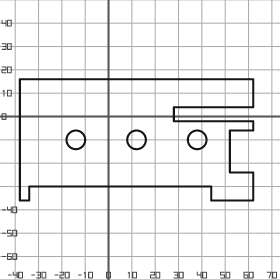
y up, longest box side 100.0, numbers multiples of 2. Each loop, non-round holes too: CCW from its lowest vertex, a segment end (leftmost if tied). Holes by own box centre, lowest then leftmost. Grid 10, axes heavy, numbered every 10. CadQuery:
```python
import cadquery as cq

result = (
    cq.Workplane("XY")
    .moveTo(-38.0, -36.0)
    .lineTo(-34.0, -36.0)
    .lineTo(-34.0, -30.0)
    .lineTo(44.0, -30.0)
    .lineTo(44.0, -36.0)
    .lineTo(62.0, -36.0)
    .lineTo(62.0, -24.0)
    .lineTo(52.0, -24.0)
    .lineTo(52.0, -6.0)
    .lineTo(62.0, -6.0)
    .lineTo(62.0, -2.0)
    .lineTo(28.0, -2.0)
    .lineTo(28.0, 4.0)
    .lineTo(62.0, 4.0)
    .lineTo(62.0, 16.0)
    .lineTo(-38.0, 16.0)
    .close()
    .moveTo(-14.0, -10.0)
    .circle(4.0)
    .moveTo(12.0, -10.0)
    .circle(4.0)
    .moveTo(38.0, -10.0)
    .circle(4.0)
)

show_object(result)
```